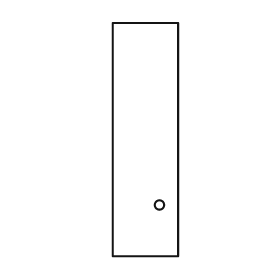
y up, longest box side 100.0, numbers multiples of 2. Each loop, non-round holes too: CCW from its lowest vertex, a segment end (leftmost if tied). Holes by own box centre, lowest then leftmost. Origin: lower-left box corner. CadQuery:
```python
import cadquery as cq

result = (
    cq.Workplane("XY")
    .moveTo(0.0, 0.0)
    .lineTo(28.0, 0.0)
    .lineTo(28.0, 100.0)
    .lineTo(0.0, 100.0)
    .close()
    .moveTo(20.0, 22.0)
    .circle(2.0)
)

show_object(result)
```